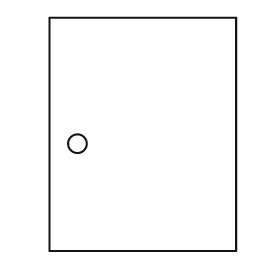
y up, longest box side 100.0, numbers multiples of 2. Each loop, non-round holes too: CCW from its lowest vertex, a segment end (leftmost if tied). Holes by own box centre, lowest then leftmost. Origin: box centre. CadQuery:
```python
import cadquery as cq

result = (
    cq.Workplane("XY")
    .moveTo(-40.0, -50.0)
    .lineTo(40.0, -50.0)
    .lineTo(40.0, 50.0)
    .lineTo(-40.0, 50.0)
    .close()
    .moveTo(-28.0, -4.0)
    .circle(4.0)
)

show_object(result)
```